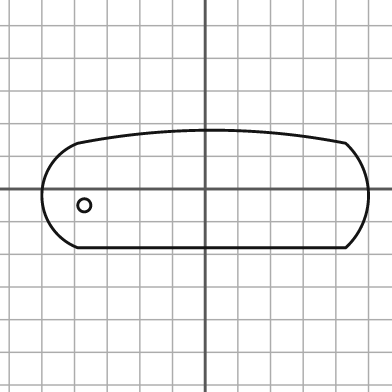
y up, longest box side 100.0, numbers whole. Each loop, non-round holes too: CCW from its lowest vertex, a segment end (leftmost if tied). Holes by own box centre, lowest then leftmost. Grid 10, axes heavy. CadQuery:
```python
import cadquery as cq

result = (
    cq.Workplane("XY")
    .moveTo(-39.0, -18.0)
    .lineTo(43.0, -18.0)
    .threePointArc((50.0, -2.0), (43.0, 14.0))
    .threePointArc((2.0, 18.0), (-39.0, 14.0))
    .threePointArc((-50.0, -2.0), (-39.0, -18.0))
    .close()
    .moveTo(-37.0, -5.0)
    .circle(2.0)
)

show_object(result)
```